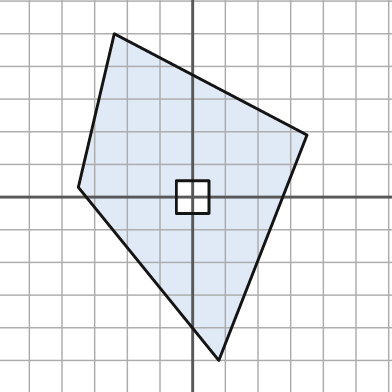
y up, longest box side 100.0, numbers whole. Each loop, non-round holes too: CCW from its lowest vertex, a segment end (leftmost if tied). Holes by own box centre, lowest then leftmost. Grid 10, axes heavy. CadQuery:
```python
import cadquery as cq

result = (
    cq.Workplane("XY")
    .moveTo(8.0, -50.0)
    .lineTo(35.0, 19.0)
    .lineTo(-24.0, 50.0)
    .lineTo(-35.0, 3.0)
    .close()
    .moveTo(-5.0, -5.0)
    .lineTo(5.0, -5.0)
    .lineTo(5.0, 5.0)
    .lineTo(-5.0, 5.0)
    .close()
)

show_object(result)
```